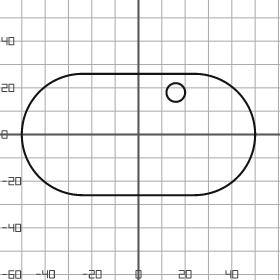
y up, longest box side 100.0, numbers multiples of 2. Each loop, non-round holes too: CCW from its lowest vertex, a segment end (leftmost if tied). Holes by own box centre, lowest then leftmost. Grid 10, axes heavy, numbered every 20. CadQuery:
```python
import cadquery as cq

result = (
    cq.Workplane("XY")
    .moveTo(-24.0, -26.0)
    .lineTo(24.0, -26.0)
    .threePointArc((50.0, 0.0), (24.0, 26.0))
    .lineTo(-24.0, 26.0)
    .threePointArc((-50.0, 0.0), (-24.0, -26.0))
    .close()
    .moveTo(16.0, 18.0)
    .circle(4.0)
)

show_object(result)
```